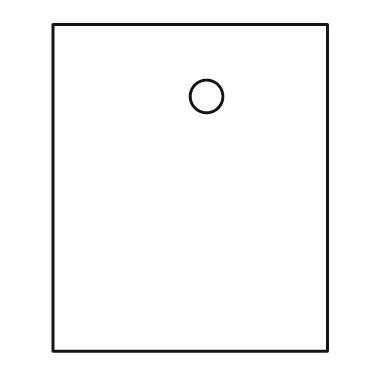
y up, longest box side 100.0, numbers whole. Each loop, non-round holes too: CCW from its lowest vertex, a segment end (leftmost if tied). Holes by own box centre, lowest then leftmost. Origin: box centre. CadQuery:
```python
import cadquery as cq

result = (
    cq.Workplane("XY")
    .moveTo(-42.0, -50.0)
    .lineTo(42.0, -50.0)
    .lineTo(42.0, 50.0)
    .lineTo(-42.0, 50.0)
    .close()
    .moveTo(5.0, 28.0)
    .circle(5.0)
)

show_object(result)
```